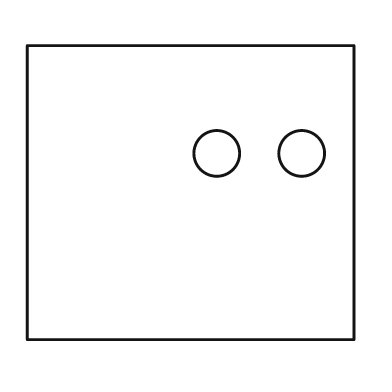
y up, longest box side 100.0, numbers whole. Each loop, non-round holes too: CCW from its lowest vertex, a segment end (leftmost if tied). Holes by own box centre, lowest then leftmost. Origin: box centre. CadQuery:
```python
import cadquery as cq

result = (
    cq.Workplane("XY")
    .moveTo(-50.0, -45.0)
    .lineTo(50.0, -45.0)
    .lineTo(50.0, 45.0)
    .lineTo(-50.0, 45.0)
    .close()
    .moveTo(8.0, 12.0)
    .circle(7.0)
    .moveTo(34.0, 12.0)
    .circle(7.0)
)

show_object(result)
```